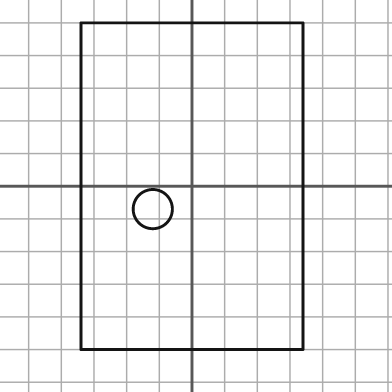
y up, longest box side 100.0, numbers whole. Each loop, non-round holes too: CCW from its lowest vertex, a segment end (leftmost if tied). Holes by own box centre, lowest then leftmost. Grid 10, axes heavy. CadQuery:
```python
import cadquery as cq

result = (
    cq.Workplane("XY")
    .moveTo(-34.0, -50.0)
    .lineTo(34.0, -50.0)
    .lineTo(34.0, 50.0)
    .lineTo(-34.0, 50.0)
    .close()
    .moveTo(-12.0, -7.0)
    .circle(6.0)
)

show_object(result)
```